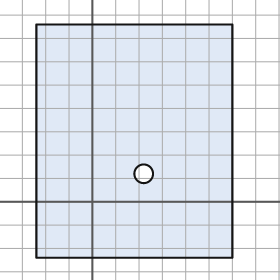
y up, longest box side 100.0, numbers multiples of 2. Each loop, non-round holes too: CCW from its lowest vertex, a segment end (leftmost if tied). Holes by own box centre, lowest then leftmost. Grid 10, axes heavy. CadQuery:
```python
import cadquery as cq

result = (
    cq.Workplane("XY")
    .moveTo(-24.0, -24.0)
    .lineTo(60.0, -24.0)
    .lineTo(60.0, 76.0)
    .lineTo(-24.0, 76.0)
    .close()
    .moveTo(22.0, 12.0)
    .circle(4.0)
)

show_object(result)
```